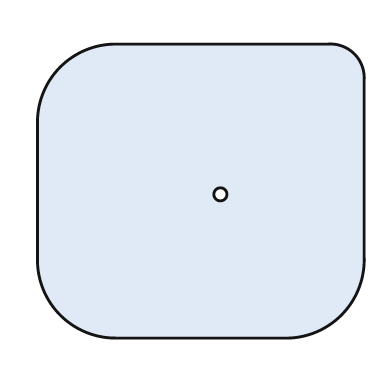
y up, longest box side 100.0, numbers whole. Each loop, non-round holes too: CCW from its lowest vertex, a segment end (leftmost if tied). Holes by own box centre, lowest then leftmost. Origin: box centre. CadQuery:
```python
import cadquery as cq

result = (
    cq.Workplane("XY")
    .moveTo(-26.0, -45.0)
    .lineTo(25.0, -45.0)
    .threePointArc((43.0, -38.0), (50.0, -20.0))
    .lineTo(50.0, 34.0)
    .threePointArc((47.0, 42.0), (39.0, 45.0))
    .lineTo(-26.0, 45.0)
    .threePointArc((-43.0, 38.0), (-50.0, 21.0))
    .lineTo(-50.0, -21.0)
    .threePointArc((-43.0, -38.0), (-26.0, -45.0))
    .close()
    .moveTo(6.0, -1.0)
    .circle(2.0)
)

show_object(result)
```